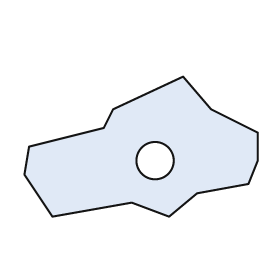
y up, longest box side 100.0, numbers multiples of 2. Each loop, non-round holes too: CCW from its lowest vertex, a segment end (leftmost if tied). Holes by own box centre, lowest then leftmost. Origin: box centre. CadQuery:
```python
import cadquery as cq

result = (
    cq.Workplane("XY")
    .moveTo(-38.0, -30.0)
    .lineTo(-4.0, -24.0)
    .lineTo(12.0, -30.0)
    .lineTo(24.0, -20.0)
    .lineTo(46.0, -16.0)
    .lineTo(50.0, -6.0)
    .lineTo(50.0, 6.0)
    .lineTo(30.0, 16.0)
    .lineTo(18.0, 30.0)
    .lineTo(-12.0, 16.0)
    .lineTo(-16.0, 8.0)
    .lineTo(-48.0, 0.0)
    .lineTo(-50.0, -12.0)
    .close()
    .moveTo(6.0, -6.0)
    .circle(8.0)
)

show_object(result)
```